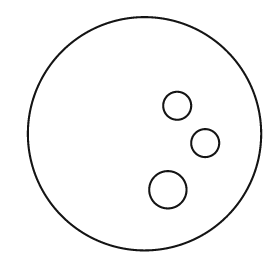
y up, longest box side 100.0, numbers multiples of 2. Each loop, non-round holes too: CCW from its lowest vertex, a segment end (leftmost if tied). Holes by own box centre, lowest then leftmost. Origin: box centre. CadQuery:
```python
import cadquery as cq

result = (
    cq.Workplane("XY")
    .moveTo(0.0, 0.0)
    .circle(50.0)
    .moveTo(10.0, -24.0)
    .circle(8.0)
    .moveTo(26.0, -4.0)
    .circle(6.0)
    .moveTo(14.0, 12.0)
    .circle(6.0)
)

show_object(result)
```